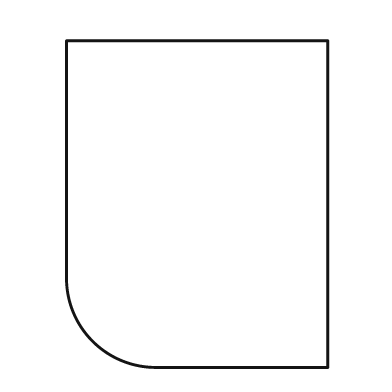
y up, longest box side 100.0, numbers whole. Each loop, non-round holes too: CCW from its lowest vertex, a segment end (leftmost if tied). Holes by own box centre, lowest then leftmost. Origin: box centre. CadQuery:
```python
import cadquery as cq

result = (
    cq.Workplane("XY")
    .moveTo(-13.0, -50.0)
    .lineTo(40.0, -50.0)
    .lineTo(40.0, 50.0)
    .lineTo(-40.0, 50.0)
    .lineTo(-40.0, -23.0)
    .threePointArc((-32.0, -42.0), (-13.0, -50.0))
    .close()
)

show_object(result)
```